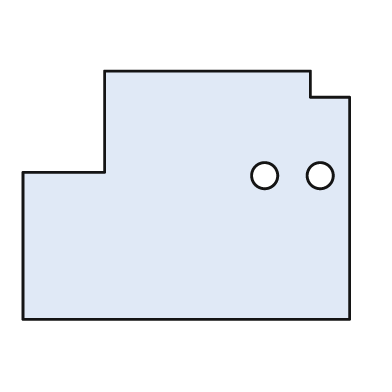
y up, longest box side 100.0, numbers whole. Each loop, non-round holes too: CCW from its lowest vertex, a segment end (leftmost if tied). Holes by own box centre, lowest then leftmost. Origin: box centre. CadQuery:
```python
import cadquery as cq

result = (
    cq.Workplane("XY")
    .moveTo(-50.0, -38.0)
    .lineTo(50.0, -38.0)
    .lineTo(50.0, 30.0)
    .lineTo(38.0, 30.0)
    .lineTo(38.0, 38.0)
    .lineTo(-25.0, 38.0)
    .lineTo(-25.0, 7.0)
    .lineTo(-50.0, 7.0)
    .close()
    .moveTo(24.0, 6.0)
    .circle(4.0)
    .moveTo(41.0, 6.0)
    .circle(4.0)
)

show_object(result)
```